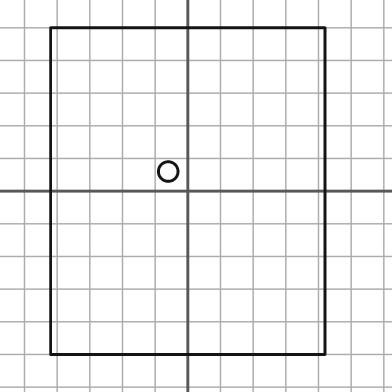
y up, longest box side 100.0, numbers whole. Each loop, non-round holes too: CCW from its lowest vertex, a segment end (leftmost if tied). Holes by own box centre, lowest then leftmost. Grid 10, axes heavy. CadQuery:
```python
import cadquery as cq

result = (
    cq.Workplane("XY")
    .moveTo(-42.0, -50.0)
    .lineTo(42.0, -50.0)
    .lineTo(42.0, 50.0)
    .lineTo(-42.0, 50.0)
    .close()
    .moveTo(-6.0, 6.0)
    .circle(3.0)
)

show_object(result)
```